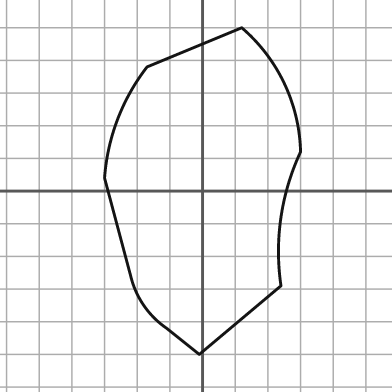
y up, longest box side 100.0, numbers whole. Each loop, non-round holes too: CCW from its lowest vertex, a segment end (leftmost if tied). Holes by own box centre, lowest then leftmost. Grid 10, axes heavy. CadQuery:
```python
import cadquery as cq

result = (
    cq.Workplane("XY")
    .moveTo(-1.0, -50.0)
    .lineTo(24.0, -29.0)
    .threePointArc((24.0, -8.0), (30.0, 12.0))
    .threePointArc((25.0, 33.0), (12.0, 50.0))
    .lineTo(-17.0, 38.0)
    .threePointArc((-26.0, 22.0), (-30.0, 4.0))
    .lineTo(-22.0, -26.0)
    .threePointArc((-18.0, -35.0), (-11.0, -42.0))
    .close()
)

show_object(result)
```